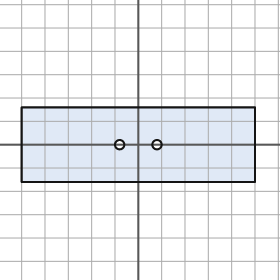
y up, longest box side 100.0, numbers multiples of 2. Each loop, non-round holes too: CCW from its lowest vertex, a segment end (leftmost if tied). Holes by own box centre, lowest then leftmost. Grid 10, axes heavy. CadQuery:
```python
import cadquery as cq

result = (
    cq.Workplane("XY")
    .moveTo(-50.0, -16.0)
    .lineTo(50.0, -16.0)
    .lineTo(50.0, 16.0)
    .lineTo(-50.0, 16.0)
    .close()
    .moveTo(-8.0, 0.0)
    .circle(2.0)
    .moveTo(8.0, 0.0)
    .circle(2.0)
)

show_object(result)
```